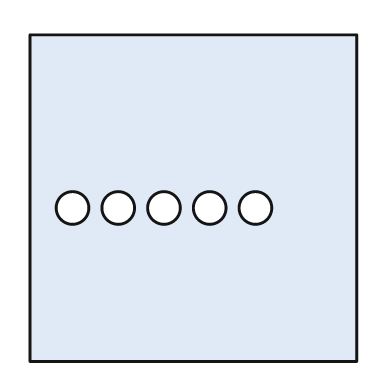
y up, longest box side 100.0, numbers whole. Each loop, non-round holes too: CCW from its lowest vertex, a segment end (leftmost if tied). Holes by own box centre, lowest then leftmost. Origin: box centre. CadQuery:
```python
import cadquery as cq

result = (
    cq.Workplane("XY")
    .moveTo(-50.0, -50.0)
    .lineTo(50.0, -50.0)
    .lineTo(50.0, 50.0)
    .lineTo(-50.0, 50.0)
    .close()
    .moveTo(-37.0, -3.0)
    .circle(5.0)
    .moveTo(-23.0, -3.0)
    .circle(5.0)
    .moveTo(-9.0, -3.0)
    .circle(5.0)
    .moveTo(5.0, -3.0)
    .circle(5.0)
    .moveTo(19.0, -3.0)
    .circle(5.0)
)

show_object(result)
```